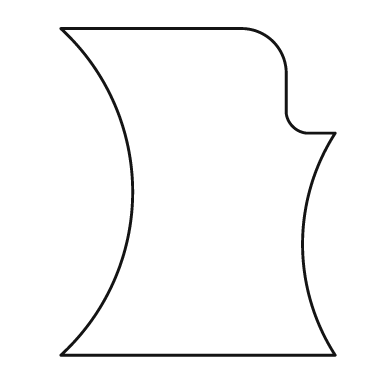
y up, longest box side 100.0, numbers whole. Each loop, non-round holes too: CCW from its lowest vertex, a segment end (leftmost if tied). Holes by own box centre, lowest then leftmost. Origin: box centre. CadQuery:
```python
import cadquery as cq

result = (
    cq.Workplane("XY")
    .moveTo(-42.0, -50.0)
    .lineTo(42.0, -50.0)
    .threePointArc((32.0, -16.0), (42.0, 18.0))
    .lineTo(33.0, 18.0)
    .threePointArc((29.0, 20.0), (27.0, 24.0))
    .lineTo(27.0, 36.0)
    .threePointArc((23.0, 46.0), (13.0, 50.0))
    .lineTo(-42.0, 50.0)
    .threePointArc((-20.0, 0.0), (-42.0, -50.0))
    .close()
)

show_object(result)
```